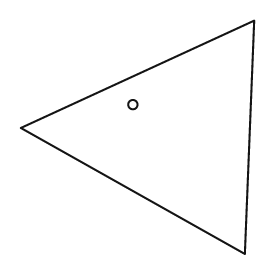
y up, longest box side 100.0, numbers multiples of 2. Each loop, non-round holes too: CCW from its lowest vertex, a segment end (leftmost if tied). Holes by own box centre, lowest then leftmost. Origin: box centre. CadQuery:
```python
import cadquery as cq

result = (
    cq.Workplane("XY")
    .moveTo(46.0, -50.0)
    .lineTo(50.0, 50.0)
    .lineTo(-50.0, 4.0)
    .close()
    .moveTo(-2.0, 14.0)
    .circle(2.0)
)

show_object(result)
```